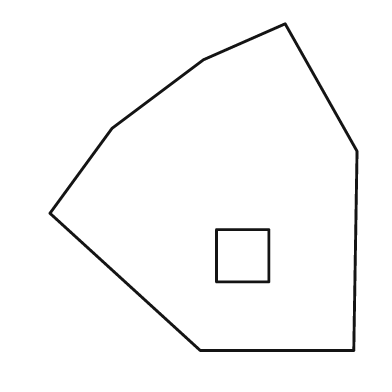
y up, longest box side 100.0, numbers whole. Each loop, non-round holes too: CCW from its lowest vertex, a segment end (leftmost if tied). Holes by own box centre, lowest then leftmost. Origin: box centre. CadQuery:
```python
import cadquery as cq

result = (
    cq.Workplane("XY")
    .moveTo(-1.0, -50.0)
    .lineTo(46.0, -50.0)
    .lineTo(47.0, 11.0)
    .lineTo(25.0, 50.0)
    .lineTo(0.0, 39.0)
    .lineTo(-28.0, 18.0)
    .lineTo(-47.0, -8.0)
    .close()
    .moveTo(4.0, -29.0)
    .lineTo(20.0, -29.0)
    .lineTo(20.0, -13.0)
    .lineTo(4.0, -13.0)
    .close()
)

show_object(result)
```